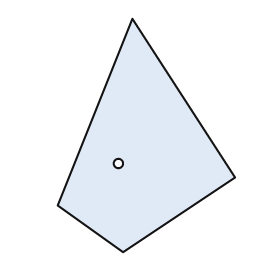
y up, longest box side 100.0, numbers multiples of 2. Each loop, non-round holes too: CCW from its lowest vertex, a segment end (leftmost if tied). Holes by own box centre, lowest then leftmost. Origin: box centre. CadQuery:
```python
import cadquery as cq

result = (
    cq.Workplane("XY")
    .moveTo(-10.0, -50.0)
    .lineTo(38.0, -18.0)
    .lineTo(-6.0, 50.0)
    .lineTo(-38.0, -30.0)
    .close()
    .moveTo(-12.0, -12.0)
    .circle(2.0)
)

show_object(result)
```